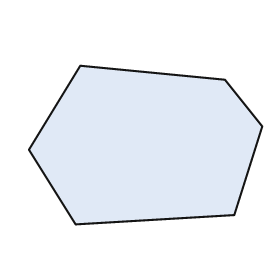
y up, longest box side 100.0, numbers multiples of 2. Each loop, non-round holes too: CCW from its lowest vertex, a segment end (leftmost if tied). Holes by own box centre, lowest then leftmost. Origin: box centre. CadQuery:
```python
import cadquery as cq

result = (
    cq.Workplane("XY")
    .moveTo(-30.0, -34.0)
    .lineTo(38.0, -30.0)
    .lineTo(50.0, 8.0)
    .lineTo(34.0, 28.0)
    .lineTo(-28.0, 34.0)
    .lineTo(-50.0, -2.0)
    .close()
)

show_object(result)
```